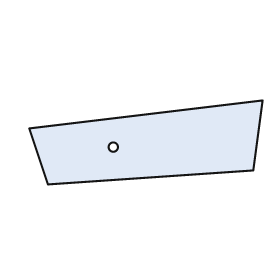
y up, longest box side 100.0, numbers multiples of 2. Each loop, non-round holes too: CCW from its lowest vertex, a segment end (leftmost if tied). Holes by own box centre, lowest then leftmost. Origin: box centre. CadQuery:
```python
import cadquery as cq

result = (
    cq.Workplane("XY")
    .moveTo(-42.0, -18.0)
    .lineTo(46.0, -12.0)
    .lineTo(50.0, 18.0)
    .lineTo(-50.0, 6.0)
    .close()
    .moveTo(-14.0, -2.0)
    .circle(2.0)
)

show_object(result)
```